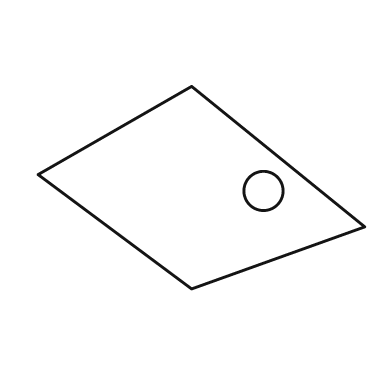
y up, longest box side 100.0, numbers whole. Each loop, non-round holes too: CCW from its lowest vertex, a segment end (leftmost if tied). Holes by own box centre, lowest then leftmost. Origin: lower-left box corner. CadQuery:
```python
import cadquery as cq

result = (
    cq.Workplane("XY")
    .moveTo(47.0, 0.0)
    .lineTo(100.0, 19.0)
    .lineTo(47.0, 62.0)
    .lineTo(0.0, 35.0)
    .close()
    .moveTo(69.0, 30.0)
    .circle(6.0)
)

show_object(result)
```